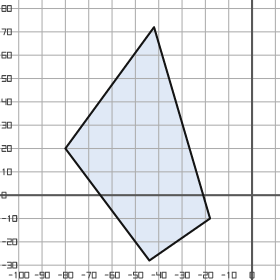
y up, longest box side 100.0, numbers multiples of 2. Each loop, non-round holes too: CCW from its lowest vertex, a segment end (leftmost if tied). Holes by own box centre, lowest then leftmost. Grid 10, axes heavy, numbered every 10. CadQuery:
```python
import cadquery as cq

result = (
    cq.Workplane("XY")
    .moveTo(-44.0, -28.0)
    .lineTo(-18.0, -10.0)
    .lineTo(-42.0, 72.0)
    .lineTo(-80.0, 20.0)
    .close()
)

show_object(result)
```